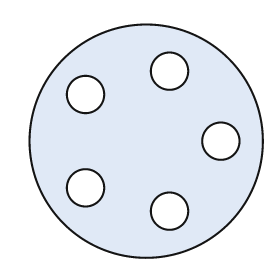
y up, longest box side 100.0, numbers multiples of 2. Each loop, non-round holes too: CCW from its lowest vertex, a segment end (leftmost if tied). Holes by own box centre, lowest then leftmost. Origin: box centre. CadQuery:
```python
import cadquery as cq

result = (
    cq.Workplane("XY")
    .moveTo(0.0, 0.0)
    .circle(50.0)
    .moveTo(10.0, -30.0)
    .circle(8.0)
    .moveTo(-26.0, -20.0)
    .circle(8.0)
    .moveTo(32.0, 0.0)
    .circle(8.0)
    .moveTo(-26.0, 20.0)
    .circle(8.0)
    .moveTo(10.0, 30.0)
    .circle(8.0)
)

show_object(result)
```